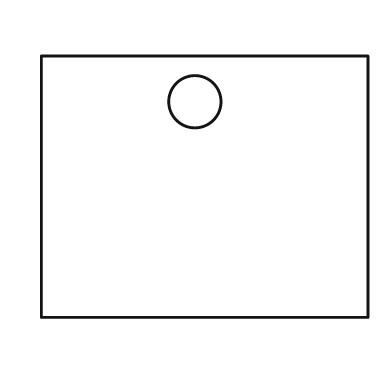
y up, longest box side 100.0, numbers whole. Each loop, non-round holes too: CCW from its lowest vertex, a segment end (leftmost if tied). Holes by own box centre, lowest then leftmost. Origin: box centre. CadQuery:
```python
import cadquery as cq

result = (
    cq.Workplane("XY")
    .moveTo(-50.0, -40.0)
    .lineTo(50.0, -40.0)
    .lineTo(50.0, 40.0)
    .lineTo(-50.0, 40.0)
    .close()
    .moveTo(-3.0, 26.0)
    .circle(8.0)
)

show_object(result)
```